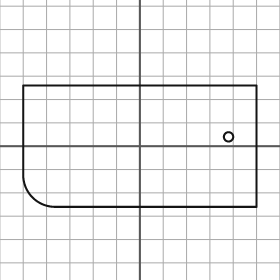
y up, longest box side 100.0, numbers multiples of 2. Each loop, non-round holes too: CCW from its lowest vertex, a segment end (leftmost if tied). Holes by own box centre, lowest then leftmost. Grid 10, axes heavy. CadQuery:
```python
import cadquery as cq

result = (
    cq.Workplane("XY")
    .moveTo(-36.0, -26.0)
    .lineTo(50.0, -26.0)
    .lineTo(50.0, 26.0)
    .lineTo(-50.0, 26.0)
    .lineTo(-50.0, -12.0)
    .threePointArc((-46.0, -22.0), (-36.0, -26.0))
    .close()
    .moveTo(38.0, 4.0)
    .circle(2.0)
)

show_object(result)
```